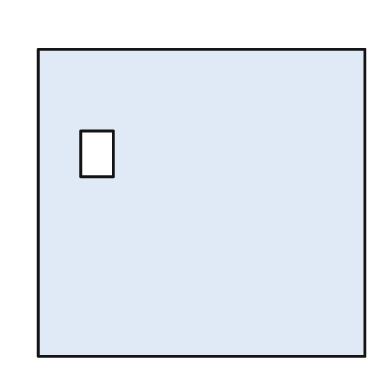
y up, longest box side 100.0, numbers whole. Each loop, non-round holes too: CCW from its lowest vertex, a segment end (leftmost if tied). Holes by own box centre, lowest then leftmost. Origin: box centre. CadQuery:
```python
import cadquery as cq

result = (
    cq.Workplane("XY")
    .moveTo(-50.0, -47.0)
    .lineTo(50.0, -47.0)
    .lineTo(50.0, 47.0)
    .lineTo(-50.0, 47.0)
    .close()
    .moveTo(-37.0, 8.0)
    .lineTo(-27.0, 8.0)
    .lineTo(-27.0, 22.0)
    .lineTo(-37.0, 22.0)
    .close()
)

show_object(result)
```